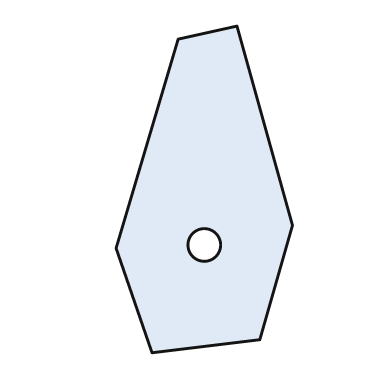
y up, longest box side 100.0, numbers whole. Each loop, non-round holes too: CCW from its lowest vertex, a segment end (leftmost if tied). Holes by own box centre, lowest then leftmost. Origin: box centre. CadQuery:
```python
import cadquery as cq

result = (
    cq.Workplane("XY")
    .moveTo(-16.0, -50.0)
    .lineTo(17.0, -46.0)
    .lineTo(27.0, -11.0)
    .lineTo(10.0, 50.0)
    .lineTo(-8.0, 46.0)
    .lineTo(-27.0, -18.0)
    .close()
    .moveTo(0.0, -17.0)
    .circle(5.0)
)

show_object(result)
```